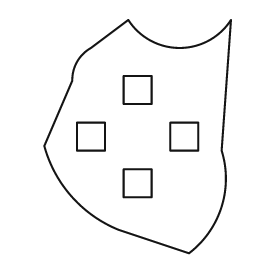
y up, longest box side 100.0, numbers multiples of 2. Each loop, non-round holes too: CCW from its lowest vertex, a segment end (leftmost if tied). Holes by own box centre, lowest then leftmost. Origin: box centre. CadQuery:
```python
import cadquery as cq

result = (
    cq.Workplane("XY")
    .moveTo(22.0, -50.0)
    .threePointArc((36.0, -30.0), (36.0, -6.0))
    .lineTo(40.0, 50.0)
    .threePointArc((18.0, 38.0), (-4.0, 50.0))
    .lineTo(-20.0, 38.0)
    .threePointArc((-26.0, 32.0), (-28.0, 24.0))
    .lineTo(-40.0, -4.0)
    .threePointArc((-28.0, -26.0), (-8.0, -40.0))
    .close()
    .moveTo(-6.0, -26.0)
    .lineTo(6.0, -26.0)
    .lineTo(6.0, -14.0)
    .lineTo(-6.0, -14.0)
    .close()
    .moveTo(-26.0, -6.0)
    .lineTo(-14.0, -6.0)
    .lineTo(-14.0, 6.0)
    .lineTo(-26.0, 6.0)
    .close()
    .moveTo(14.0, -6.0)
    .lineTo(26.0, -6.0)
    .lineTo(26.0, 6.0)
    .lineTo(14.0, 6.0)
    .close()
    .moveTo(-6.0, 14.0)
    .lineTo(6.0, 14.0)
    .lineTo(6.0, 26.0)
    .lineTo(-6.0, 26.0)
    .close()
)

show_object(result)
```